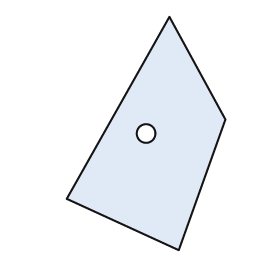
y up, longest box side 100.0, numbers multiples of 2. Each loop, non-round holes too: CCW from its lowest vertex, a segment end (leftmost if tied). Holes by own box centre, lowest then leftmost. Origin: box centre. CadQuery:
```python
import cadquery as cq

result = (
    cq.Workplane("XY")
    .moveTo(14.0, -50.0)
    .lineTo(34.0, 6.0)
    .lineTo(10.0, 50.0)
    .lineTo(-34.0, -28.0)
    .close()
    .moveTo(0.0, 0.0)
    .circle(4.0)
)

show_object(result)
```